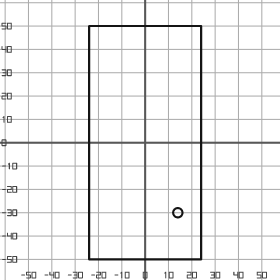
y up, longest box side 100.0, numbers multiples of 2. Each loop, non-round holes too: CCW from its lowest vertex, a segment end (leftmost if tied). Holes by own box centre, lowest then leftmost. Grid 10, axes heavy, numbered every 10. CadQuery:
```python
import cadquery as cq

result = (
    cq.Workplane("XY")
    .moveTo(-24.0, -50.0)
    .lineTo(24.0, -50.0)
    .lineTo(24.0, 50.0)
    .lineTo(-24.0, 50.0)
    .close()
    .moveTo(14.0, -30.0)
    .circle(2.0)
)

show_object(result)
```